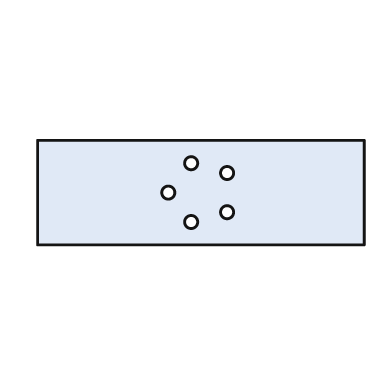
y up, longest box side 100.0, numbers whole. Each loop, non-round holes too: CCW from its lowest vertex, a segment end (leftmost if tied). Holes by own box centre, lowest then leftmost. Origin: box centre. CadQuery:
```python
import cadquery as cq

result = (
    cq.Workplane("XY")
    .moveTo(-50.0, -16.0)
    .lineTo(50.0, -16.0)
    .lineTo(50.0, 16.0)
    .lineTo(-50.0, 16.0)
    .close()
    .moveTo(-3.0, -9.0)
    .circle(2.0)
    .moveTo(8.0, -6.0)
    .circle(2.0)
    .moveTo(-10.0, 0.0)
    .circle(2.0)
    .moveTo(8.0, 6.0)
    .circle(2.0)
    .moveTo(-3.0, 9.0)
    .circle(2.0)
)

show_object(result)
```